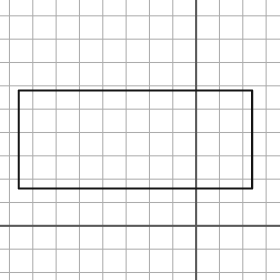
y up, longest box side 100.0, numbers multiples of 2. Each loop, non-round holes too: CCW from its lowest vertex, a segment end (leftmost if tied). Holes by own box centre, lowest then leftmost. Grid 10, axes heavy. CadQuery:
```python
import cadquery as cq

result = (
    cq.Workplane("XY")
    .moveTo(-76.0, 16.0)
    .lineTo(24.0, 16.0)
    .lineTo(24.0, 58.0)
    .lineTo(-76.0, 58.0)
    .close()
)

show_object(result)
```